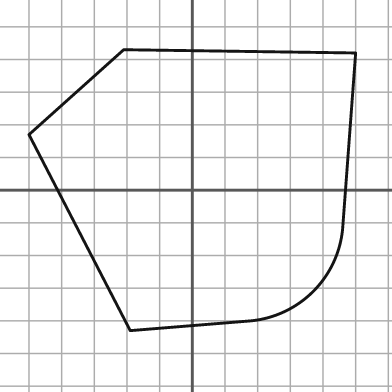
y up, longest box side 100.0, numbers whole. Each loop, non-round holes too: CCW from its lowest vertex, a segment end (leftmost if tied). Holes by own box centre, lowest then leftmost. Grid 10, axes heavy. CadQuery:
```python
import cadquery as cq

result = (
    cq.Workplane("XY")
    .moveTo(-19.0, -43.0)
    .lineTo(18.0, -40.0)
    .threePointArc((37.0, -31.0), (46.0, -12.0))
    .lineTo(50.0, 42.0)
    .lineTo(-21.0, 43.0)
    .lineTo(-50.0, 17.0)
    .close()
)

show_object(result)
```